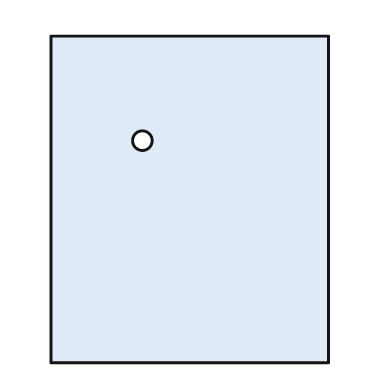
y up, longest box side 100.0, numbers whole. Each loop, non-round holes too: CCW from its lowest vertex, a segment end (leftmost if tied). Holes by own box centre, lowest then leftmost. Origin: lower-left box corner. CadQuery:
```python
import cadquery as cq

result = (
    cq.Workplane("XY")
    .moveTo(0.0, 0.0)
    .lineTo(85.0, 0.0)
    .lineTo(85.0, 100.0)
    .lineTo(0.0, 100.0)
    .close()
    .moveTo(28.0, 68.0)
    .circle(3.0)
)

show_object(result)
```